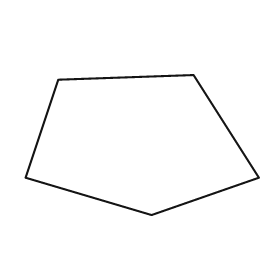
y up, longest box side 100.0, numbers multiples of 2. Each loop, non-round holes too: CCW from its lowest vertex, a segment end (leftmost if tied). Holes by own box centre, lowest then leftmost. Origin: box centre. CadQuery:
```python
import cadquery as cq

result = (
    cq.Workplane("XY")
    .moveTo(4.0, -30.0)
    .lineTo(50.0, -14.0)
    .lineTo(22.0, 30.0)
    .lineTo(-36.0, 28.0)
    .lineTo(-50.0, -14.0)
    .close()
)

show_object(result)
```